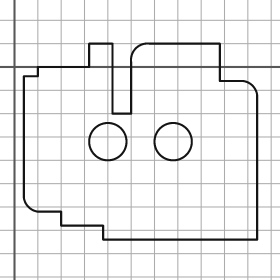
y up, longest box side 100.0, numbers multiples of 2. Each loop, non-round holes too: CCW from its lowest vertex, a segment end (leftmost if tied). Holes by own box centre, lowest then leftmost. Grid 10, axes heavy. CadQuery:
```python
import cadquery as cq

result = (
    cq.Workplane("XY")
    .moveTo(38.0, -74.0)
    .lineTo(104.0, -74.0)
    .lineTo(104.0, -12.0)
    .threePointArc((102.0, -8.0), (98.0, -6.0))
    .lineTo(88.0, -6.0)
    .lineTo(88.0, 10.0)
    .lineTo(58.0, 10.0)
    .threePointArc((52.0, 8.0), (50.0, 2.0))
    .lineTo(50.0, -20.0)
    .lineTo(42.0, -20.0)
    .lineTo(42.0, 10.0)
    .lineTo(32.0, 10.0)
    .lineTo(32.0, 0.0)
    .lineTo(10.0, 0.0)
    .lineTo(10.0, -4.0)
    .lineTo(4.0, -4.0)
    .lineTo(4.0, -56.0)
    .threePointArc((6.0, -60.0), (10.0, -62.0))
    .lineTo(20.0, -62.0)
    .lineTo(20.0, -68.0)
    .lineTo(38.0, -68.0)
    .close()
    .moveTo(40.0, -32.0)
    .circle(8.0)
    .moveTo(68.0, -32.0)
    .circle(8.0)
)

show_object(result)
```